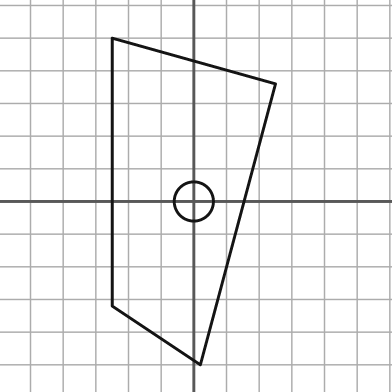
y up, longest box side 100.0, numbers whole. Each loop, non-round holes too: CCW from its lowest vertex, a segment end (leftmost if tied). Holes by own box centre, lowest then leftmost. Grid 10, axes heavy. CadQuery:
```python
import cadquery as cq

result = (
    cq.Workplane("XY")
    .moveTo(2.0, -50.0)
    .lineTo(25.0, 36.0)
    .lineTo(-25.0, 50.0)
    .lineTo(-25.0, -32.0)
    .close()
    .moveTo(0.0, 0.0)
    .circle(6.0)
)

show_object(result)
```